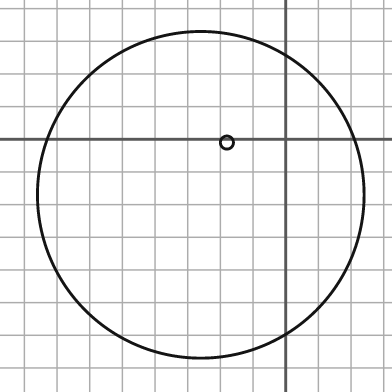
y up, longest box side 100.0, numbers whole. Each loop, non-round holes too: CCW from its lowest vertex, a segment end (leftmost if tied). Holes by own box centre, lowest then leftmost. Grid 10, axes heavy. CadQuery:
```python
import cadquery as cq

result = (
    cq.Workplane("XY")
    .moveTo(-26.0, -17.0)
    .circle(50.0)
    .moveTo(-18.0, -1.0)
    .circle(2.0)
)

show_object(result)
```